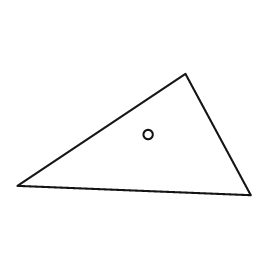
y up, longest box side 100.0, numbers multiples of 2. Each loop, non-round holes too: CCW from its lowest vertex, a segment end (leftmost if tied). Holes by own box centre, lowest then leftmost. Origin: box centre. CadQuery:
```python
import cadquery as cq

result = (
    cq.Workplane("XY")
    .moveTo(50.0, -26.0)
    .lineTo(22.0, 26.0)
    .lineTo(-50.0, -22.0)
    .close()
    .moveTo(6.0, 0.0)
    .circle(2.0)
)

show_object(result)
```